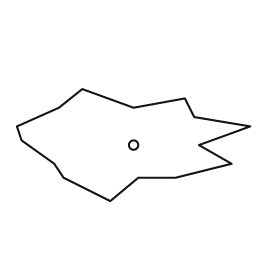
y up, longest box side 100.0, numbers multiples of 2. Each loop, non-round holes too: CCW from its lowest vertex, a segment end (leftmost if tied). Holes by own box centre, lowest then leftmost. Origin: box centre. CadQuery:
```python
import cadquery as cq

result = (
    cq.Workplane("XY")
    .moveTo(-10.0, -24.0)
    .lineTo(2.0, -14.0)
    .lineTo(18.0, -14.0)
    .lineTo(42.0, -8.0)
    .lineTo(28.0, 0.0)
    .lineTo(50.0, 8.0)
    .lineTo(26.0, 12.0)
    .lineTo(22.0, 20.0)
    .lineTo(0.0, 16.0)
    .lineTo(-22.0, 24.0)
    .lineTo(-32.0, 16.0)
    .lineTo(-50.0, 8.0)
    .lineTo(-48.0, 2.0)
    .lineTo(-34.0, -8.0)
    .lineTo(-30.0, -14.0)
    .close()
    .moveTo(0.0, 0.0)
    .circle(2.0)
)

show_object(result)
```